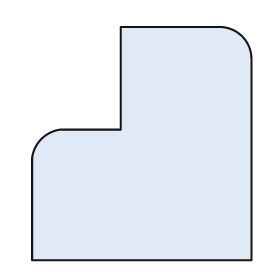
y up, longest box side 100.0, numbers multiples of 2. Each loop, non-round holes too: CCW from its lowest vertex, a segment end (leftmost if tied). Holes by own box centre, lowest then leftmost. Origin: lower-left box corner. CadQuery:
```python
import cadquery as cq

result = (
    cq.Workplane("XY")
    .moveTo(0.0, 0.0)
    .lineTo(94.0, 0.0)
    .lineTo(94.0, 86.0)
    .threePointArc((90.0, 96.0), (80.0, 100.0))
    .lineTo(38.0, 100.0)
    .lineTo(38.0, 56.0)
    .lineTo(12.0, 56.0)
    .threePointArc((4.0, 52.0), (0.0, 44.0))
    .close()
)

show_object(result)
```